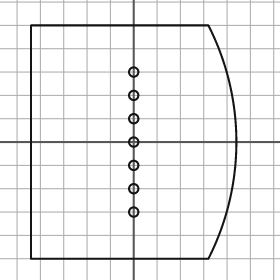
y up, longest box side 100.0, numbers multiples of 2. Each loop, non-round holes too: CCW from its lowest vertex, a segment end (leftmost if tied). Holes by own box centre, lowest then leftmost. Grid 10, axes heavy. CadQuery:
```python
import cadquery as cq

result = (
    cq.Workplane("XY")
    .moveTo(-44.0, -50.0)
    .lineTo(32.0, -50.0)
    .threePointArc((44.0, 0.0), (32.0, 50.0))
    .lineTo(-44.0, 50.0)
    .close()
    .moveTo(0.0, -30.0)
    .circle(2.0)
    .moveTo(0.0, -20.0)
    .circle(2.0)
    .moveTo(0.0, -10.0)
    .circle(2.0)
    .moveTo(0.0, 0.0)
    .circle(2.0)
    .moveTo(0.0, 10.0)
    .circle(2.0)
    .moveTo(0.0, 20.0)
    .circle(2.0)
    .moveTo(0.0, 30.0)
    .circle(2.0)
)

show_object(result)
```